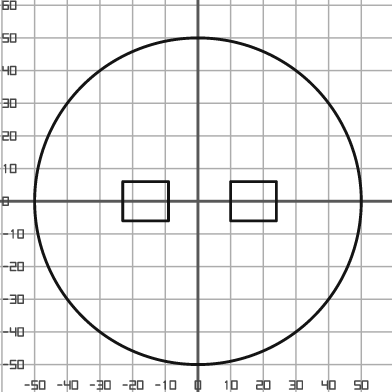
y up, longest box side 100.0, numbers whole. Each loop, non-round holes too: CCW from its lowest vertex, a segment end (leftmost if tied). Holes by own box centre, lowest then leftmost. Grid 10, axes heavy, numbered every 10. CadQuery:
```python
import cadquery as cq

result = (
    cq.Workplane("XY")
    .moveTo(0.0, 0.0)
    .circle(50.0)
    .moveTo(-23.0, -6.0)
    .lineTo(-9.0, -6.0)
    .lineTo(-9.0, 6.0)
    .lineTo(-23.0, 6.0)
    .close()
    .moveTo(10.0, -6.0)
    .lineTo(24.0, -6.0)
    .lineTo(24.0, 6.0)
    .lineTo(10.0, 6.0)
    .close()
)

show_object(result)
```